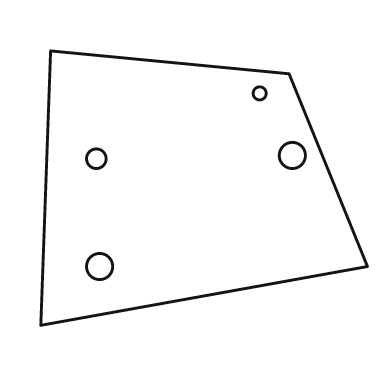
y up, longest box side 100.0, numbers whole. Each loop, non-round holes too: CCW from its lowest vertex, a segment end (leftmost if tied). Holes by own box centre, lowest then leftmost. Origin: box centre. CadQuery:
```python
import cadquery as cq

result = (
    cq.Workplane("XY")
    .moveTo(-50.0, -42.0)
    .lineTo(50.0, -24.0)
    .lineTo(26.0, 35.0)
    .lineTo(-47.0, 42.0)
    .close()
    .moveTo(-32.0, -24.0)
    .circle(4.0)
    .moveTo(-33.0, 9.0)
    .circle(3.0)
    .moveTo(27.0, 10.0)
    .circle(4.0)
    .moveTo(17.0, 29.0)
    .circle(2.0)
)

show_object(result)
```